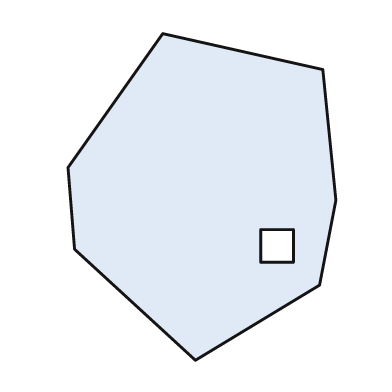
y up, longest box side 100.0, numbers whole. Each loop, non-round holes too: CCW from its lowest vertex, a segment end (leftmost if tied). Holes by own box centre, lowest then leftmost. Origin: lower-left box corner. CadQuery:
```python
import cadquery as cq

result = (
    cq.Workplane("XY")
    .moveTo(39.0, 0.0)
    .lineTo(77.0, 23.0)
    .lineTo(82.0, 49.0)
    .lineTo(78.0, 89.0)
    .lineTo(29.0, 100.0)
    .lineTo(0.0, 59.0)
    .lineTo(2.0, 34.0)
    .close()
    .moveTo(59.0, 30.0)
    .lineTo(69.0, 30.0)
    .lineTo(69.0, 40.0)
    .lineTo(59.0, 40.0)
    .close()
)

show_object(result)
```